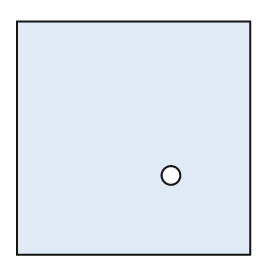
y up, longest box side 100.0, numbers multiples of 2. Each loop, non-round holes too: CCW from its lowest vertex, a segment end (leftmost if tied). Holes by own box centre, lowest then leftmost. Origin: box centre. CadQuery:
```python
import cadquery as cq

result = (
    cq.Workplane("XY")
    .moveTo(-50.0, -50.0)
    .lineTo(50.0, -50.0)
    .lineTo(50.0, 50.0)
    .lineTo(-50.0, 50.0)
    .close()
    .moveTo(16.0, -16.0)
    .circle(4.0)
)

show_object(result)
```